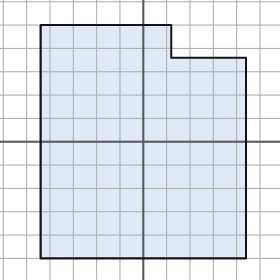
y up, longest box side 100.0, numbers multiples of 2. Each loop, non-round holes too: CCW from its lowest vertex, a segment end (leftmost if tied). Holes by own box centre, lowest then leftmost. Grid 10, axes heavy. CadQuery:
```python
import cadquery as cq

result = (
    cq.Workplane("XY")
    .moveTo(-44.0, -50.0)
    .lineTo(44.0, -50.0)
    .lineTo(44.0, 36.0)
    .lineTo(12.0, 36.0)
    .lineTo(12.0, 50.0)
    .lineTo(-44.0, 50.0)
    .close()
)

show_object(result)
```